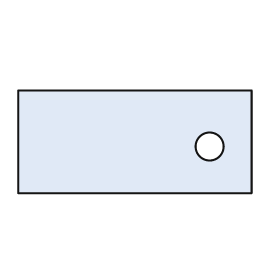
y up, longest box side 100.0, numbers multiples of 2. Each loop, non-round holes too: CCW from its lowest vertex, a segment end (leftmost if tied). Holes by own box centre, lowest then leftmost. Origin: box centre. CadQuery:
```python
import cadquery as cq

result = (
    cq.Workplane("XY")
    .moveTo(-50.0, -22.0)
    .lineTo(50.0, -22.0)
    .lineTo(50.0, 22.0)
    .lineTo(-50.0, 22.0)
    .close()
    .moveTo(32.0, -2.0)
    .circle(6.0)
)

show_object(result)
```